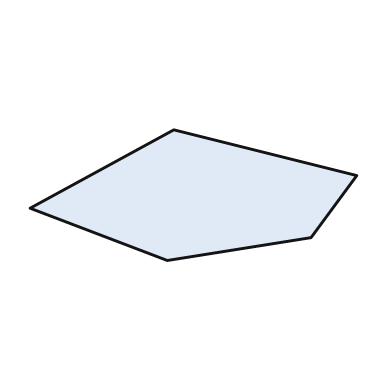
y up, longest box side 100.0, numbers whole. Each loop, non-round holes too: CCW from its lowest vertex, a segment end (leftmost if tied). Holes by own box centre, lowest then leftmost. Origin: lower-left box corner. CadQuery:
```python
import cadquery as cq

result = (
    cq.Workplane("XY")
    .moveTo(42.0, 0.0)
    .lineTo(86.0, 7.0)
    .lineTo(100.0, 26.0)
    .lineTo(44.0, 40.0)
    .lineTo(0.0, 16.0)
    .close()
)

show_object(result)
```